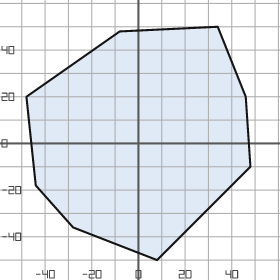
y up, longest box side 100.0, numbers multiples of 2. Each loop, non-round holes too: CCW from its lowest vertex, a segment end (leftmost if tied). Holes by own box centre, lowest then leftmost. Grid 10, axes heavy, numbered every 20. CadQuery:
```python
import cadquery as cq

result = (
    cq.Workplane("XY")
    .moveTo(8.0, -50.0)
    .lineTo(48.0, -10.0)
    .lineTo(46.0, 20.0)
    .lineTo(34.0, 50.0)
    .lineTo(-8.0, 48.0)
    .lineTo(-48.0, 20.0)
    .lineTo(-44.0, -18.0)
    .lineTo(-28.0, -36.0)
    .close()
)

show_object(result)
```